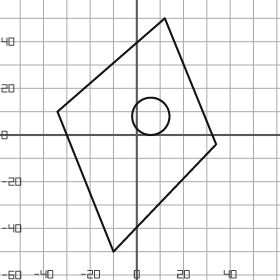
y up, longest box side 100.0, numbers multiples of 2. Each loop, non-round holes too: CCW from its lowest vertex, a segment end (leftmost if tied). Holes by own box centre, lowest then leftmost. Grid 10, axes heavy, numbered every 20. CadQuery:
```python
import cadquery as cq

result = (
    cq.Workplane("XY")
    .moveTo(-10.0, -50.0)
    .lineTo(34.0, -4.0)
    .lineTo(12.0, 50.0)
    .lineTo(-34.0, 10.0)
    .close()
    .moveTo(6.0, 8.0)
    .circle(8.0)
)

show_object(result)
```